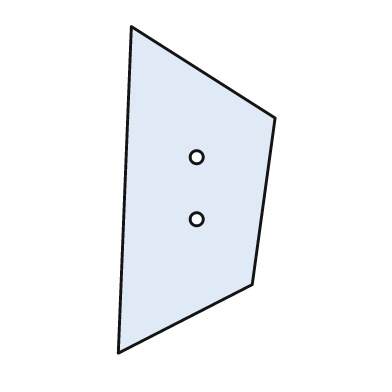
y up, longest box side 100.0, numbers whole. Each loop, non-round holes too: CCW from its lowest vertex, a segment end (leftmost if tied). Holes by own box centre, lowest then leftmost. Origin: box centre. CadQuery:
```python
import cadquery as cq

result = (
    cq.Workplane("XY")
    .moveTo(-24.0, -50.0)
    .lineTo(17.0, -29.0)
    .lineTo(24.0, 22.0)
    .lineTo(-20.0, 50.0)
    .close()
    .moveTo(0.0, -9.0)
    .circle(2.0)
    .moveTo(0.0, 10.0)
    .circle(2.0)
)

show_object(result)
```